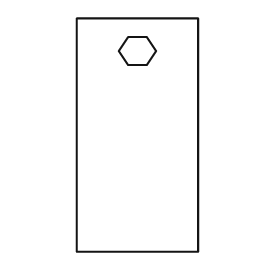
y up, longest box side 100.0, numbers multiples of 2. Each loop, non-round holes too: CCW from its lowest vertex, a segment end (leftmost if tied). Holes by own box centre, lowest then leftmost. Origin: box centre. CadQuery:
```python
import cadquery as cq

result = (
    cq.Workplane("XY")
    .moveTo(-26.0, -50.0)
    .lineTo(26.0, -50.0)
    .lineTo(26.0, 50.0)
    .lineTo(-26.0, 50.0)
    .close()
    .moveTo(-4.0, 30.0)
    .lineTo(4.0, 30.0)
    .lineTo(8.0, 36.0)
    .lineTo(4.0, 42.0)
    .lineTo(-4.0, 42.0)
    .lineTo(-8.0, 36.0)
    .close()
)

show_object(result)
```